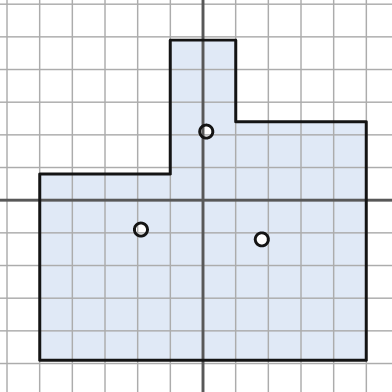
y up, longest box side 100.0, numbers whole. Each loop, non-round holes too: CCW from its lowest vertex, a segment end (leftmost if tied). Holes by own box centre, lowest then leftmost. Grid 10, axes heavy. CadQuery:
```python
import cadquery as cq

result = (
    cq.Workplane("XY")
    .moveTo(-50.0, -49.0)
    .lineTo(50.0, -49.0)
    .lineTo(50.0, 24.0)
    .lineTo(10.0, 24.0)
    .lineTo(10.0, 49.0)
    .lineTo(-10.0, 49.0)
    .lineTo(-10.0, 8.0)
    .lineTo(-50.0, 8.0)
    .close()
    .moveTo(18.0, -12.0)
    .circle(2.0)
    .moveTo(-19.0, -9.0)
    .circle(2.0)
    .moveTo(1.0, 21.0)
    .circle(2.0)
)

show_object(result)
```